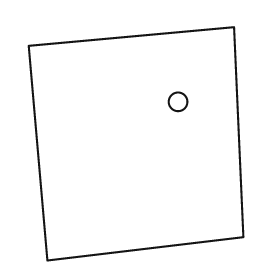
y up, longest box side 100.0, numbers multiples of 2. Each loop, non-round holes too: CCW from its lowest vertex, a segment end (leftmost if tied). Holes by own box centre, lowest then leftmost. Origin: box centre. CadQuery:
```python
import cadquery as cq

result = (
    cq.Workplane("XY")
    .moveTo(-38.0, -50.0)
    .lineTo(46.0, -40.0)
    .lineTo(42.0, 50.0)
    .lineTo(-46.0, 42.0)
    .close()
    .moveTo(18.0, 18.0)
    .circle(4.0)
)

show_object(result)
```